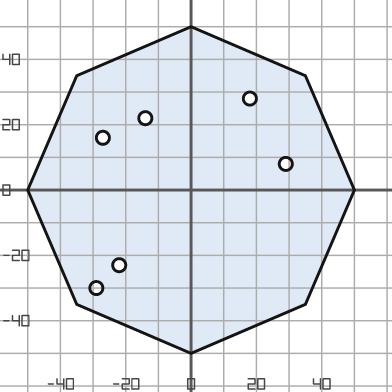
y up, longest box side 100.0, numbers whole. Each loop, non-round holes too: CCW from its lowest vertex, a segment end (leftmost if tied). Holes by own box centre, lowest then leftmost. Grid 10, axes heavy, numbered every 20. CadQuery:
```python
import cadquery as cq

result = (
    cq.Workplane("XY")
    .moveTo(0.0, -50.0)
    .lineTo(35.0, -35.0)
    .lineTo(50.0, 0.0)
    .lineTo(35.0, 35.0)
    .lineTo(0.0, 50.0)
    .lineTo(-35.0, 35.0)
    .lineTo(-50.0, 0.0)
    .lineTo(-35.0, -35.0)
    .close()
    .moveTo(-29.0, -30.0)
    .circle(2.0)
    .moveTo(-22.0, -23.0)
    .circle(2.0)
    .moveTo(29.0, 8.0)
    .circle(2.0)
    .moveTo(-27.0, 16.0)
    .circle(2.0)
    .moveTo(-14.0, 22.0)
    .circle(2.0)
    .moveTo(18.0, 28.0)
    .circle(2.0)
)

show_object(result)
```